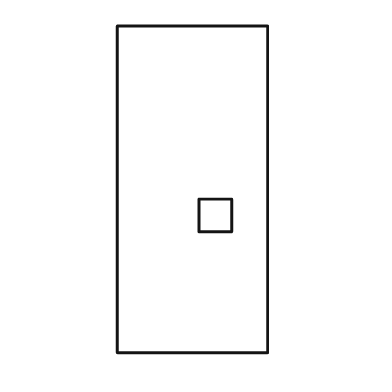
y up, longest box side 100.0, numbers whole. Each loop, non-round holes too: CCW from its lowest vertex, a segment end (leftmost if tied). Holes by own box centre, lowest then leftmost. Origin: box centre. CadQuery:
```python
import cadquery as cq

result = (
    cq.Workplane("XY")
    .moveTo(-23.0, -50.0)
    .lineTo(23.0, -50.0)
    .lineTo(23.0, 50.0)
    .lineTo(-23.0, 50.0)
    .close()
    .moveTo(2.0, -13.0)
    .lineTo(12.0, -13.0)
    .lineTo(12.0, -3.0)
    .lineTo(2.0, -3.0)
    .close()
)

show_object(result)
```